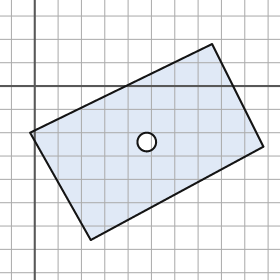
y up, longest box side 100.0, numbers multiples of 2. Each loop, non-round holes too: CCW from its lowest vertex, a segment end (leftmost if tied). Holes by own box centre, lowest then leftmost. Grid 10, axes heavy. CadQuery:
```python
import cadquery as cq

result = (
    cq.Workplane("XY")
    .moveTo(24.0, -66.0)
    .lineTo(98.0, -26.0)
    .lineTo(76.0, 18.0)
    .lineTo(-2.0, -20.0)
    .close()
    .moveTo(48.0, -24.0)
    .circle(4.0)
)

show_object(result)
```